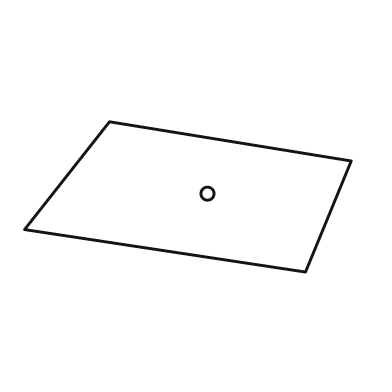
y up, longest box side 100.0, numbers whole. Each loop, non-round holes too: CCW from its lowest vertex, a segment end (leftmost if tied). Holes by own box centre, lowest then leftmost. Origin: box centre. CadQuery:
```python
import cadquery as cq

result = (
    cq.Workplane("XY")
    .moveTo(36.0, -23.0)
    .lineTo(50.0, 11.0)
    .lineTo(-24.0, 23.0)
    .lineTo(-50.0, -10.0)
    .close()
    .moveTo(6.0, 1.0)
    .circle(2.0)
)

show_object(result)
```